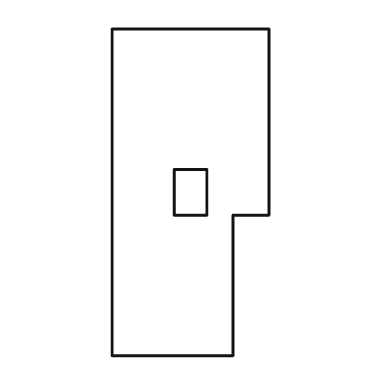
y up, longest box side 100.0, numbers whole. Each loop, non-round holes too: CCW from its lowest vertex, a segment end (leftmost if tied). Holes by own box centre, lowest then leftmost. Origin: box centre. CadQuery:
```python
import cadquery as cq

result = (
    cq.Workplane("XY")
    .moveTo(-24.0, -50.0)
    .lineTo(13.0, -50.0)
    .lineTo(13.0, -7.0)
    .lineTo(24.0, -7.0)
    .lineTo(24.0, 50.0)
    .lineTo(-24.0, 50.0)
    .close()
    .moveTo(-5.0, -7.0)
    .lineTo(5.0, -7.0)
    .lineTo(5.0, 7.0)
    .lineTo(-5.0, 7.0)
    .close()
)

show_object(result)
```